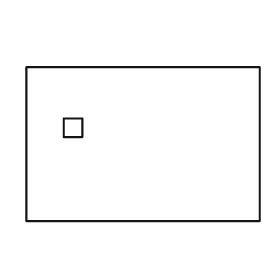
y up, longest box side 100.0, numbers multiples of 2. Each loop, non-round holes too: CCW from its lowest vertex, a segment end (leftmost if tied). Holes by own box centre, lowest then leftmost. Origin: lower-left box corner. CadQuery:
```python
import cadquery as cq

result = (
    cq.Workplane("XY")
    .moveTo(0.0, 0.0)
    .lineTo(100.0, 0.0)
    .lineTo(100.0, 66.0)
    .lineTo(0.0, 66.0)
    .close()
    .moveTo(16.0, 36.0)
    .lineTo(24.0, 36.0)
    .lineTo(24.0, 44.0)
    .lineTo(16.0, 44.0)
    .close()
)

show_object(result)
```